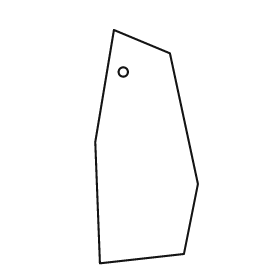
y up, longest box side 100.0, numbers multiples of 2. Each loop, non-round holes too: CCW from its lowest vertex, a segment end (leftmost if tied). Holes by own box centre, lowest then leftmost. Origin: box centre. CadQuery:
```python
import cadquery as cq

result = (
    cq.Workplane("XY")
    .moveTo(-20.0, -50.0)
    .lineTo(16.0, -46.0)
    .lineTo(22.0, -16.0)
    .lineTo(10.0, 40.0)
    .lineTo(-14.0, 50.0)
    .lineTo(-22.0, 2.0)
    .close()
    .moveTo(-10.0, 32.0)
    .circle(2.0)
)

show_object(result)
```